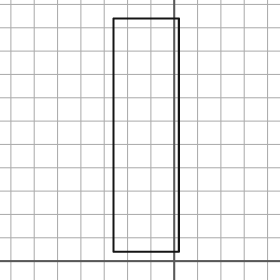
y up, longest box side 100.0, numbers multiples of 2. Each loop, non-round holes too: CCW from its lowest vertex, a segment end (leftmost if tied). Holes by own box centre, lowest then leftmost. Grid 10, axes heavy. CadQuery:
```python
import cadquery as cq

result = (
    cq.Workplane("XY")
    .moveTo(-26.0, 4.0)
    .lineTo(2.0, 4.0)
    .lineTo(2.0, 104.0)
    .lineTo(-26.0, 104.0)
    .close()
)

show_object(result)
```